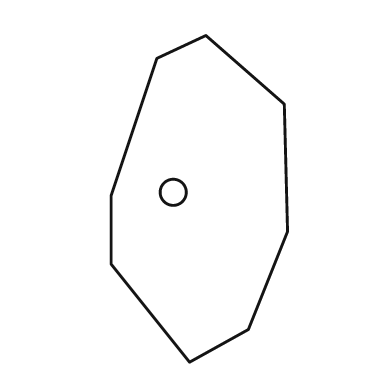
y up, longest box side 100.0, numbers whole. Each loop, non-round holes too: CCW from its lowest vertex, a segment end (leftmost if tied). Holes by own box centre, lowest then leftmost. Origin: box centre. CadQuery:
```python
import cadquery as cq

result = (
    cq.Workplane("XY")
    .moveTo(-3.0, -50.0)
    .lineTo(15.0, -40.0)
    .lineTo(27.0, -10.0)
    .lineTo(26.0, 29.0)
    .lineTo(2.0, 50.0)
    .lineTo(-13.0, 43.0)
    .lineTo(-27.0, 1.0)
    .lineTo(-27.0, -20.0)
    .close()
    .moveTo(-8.0, 2.0)
    .circle(4.0)
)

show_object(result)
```